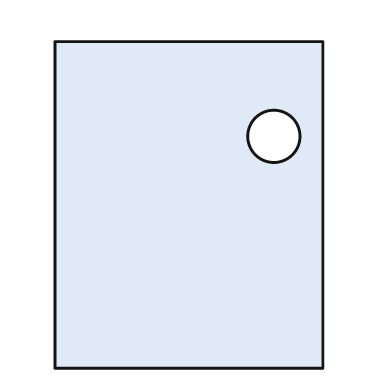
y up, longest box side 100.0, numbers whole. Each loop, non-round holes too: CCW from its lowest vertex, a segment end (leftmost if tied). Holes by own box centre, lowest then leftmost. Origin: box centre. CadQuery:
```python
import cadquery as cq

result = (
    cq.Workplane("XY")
    .moveTo(-41.0, -50.0)
    .lineTo(41.0, -50.0)
    .lineTo(41.0, 50.0)
    .lineTo(-41.0, 50.0)
    .close()
    .moveTo(26.0, 21.0)
    .circle(8.0)
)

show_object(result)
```